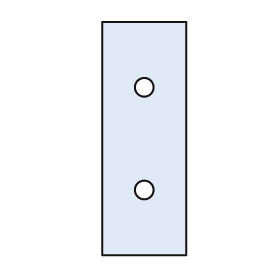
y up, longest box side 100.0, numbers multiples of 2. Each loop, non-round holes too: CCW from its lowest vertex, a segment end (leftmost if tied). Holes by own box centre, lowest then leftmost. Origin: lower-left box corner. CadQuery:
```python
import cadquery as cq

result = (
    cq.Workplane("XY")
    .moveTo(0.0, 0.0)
    .lineTo(36.0, 0.0)
    .lineTo(36.0, 100.0)
    .lineTo(0.0, 100.0)
    .close()
    .moveTo(18.0, 28.0)
    .circle(4.0)
    .moveTo(18.0, 72.0)
    .circle(4.0)
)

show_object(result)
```